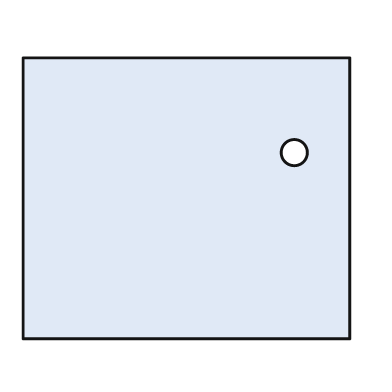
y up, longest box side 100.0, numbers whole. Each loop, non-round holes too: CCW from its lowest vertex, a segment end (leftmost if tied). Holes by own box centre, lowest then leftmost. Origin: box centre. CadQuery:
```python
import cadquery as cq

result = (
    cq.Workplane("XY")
    .moveTo(-50.0, -43.0)
    .lineTo(50.0, -43.0)
    .lineTo(50.0, 43.0)
    .lineTo(-50.0, 43.0)
    .close()
    .moveTo(33.0, 14.0)
    .circle(4.0)
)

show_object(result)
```